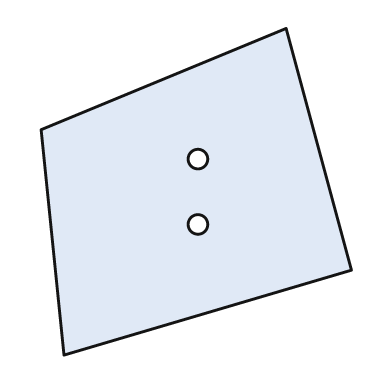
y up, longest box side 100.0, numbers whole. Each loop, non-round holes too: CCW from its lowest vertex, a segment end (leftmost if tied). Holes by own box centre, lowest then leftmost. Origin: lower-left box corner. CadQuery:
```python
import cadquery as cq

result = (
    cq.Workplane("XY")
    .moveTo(7.0, 0.0)
    .lineTo(95.0, 26.0)
    .lineTo(75.0, 100.0)
    .lineTo(0.0, 69.0)
    .close()
    .moveTo(48.0, 40.0)
    .circle(3.0)
    .moveTo(48.0, 60.0)
    .circle(3.0)
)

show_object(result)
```